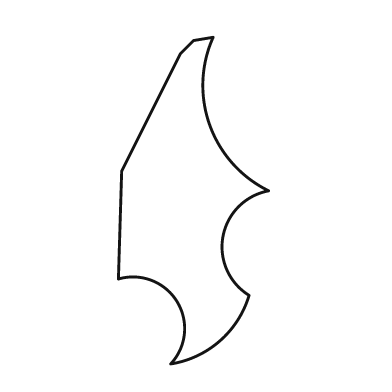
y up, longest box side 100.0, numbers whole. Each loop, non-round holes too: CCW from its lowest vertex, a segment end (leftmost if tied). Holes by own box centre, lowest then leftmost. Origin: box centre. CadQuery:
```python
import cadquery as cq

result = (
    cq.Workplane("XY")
    .moveTo(-7.0, -50.0)
    .threePointArc((8.0, -43.0), (17.0, -29.0))
    .threePointArc((9.0, -11.0), (23.0, 3.0))
    .threePointArc((5.0, 23.0), (6.0, 50.0))
    .lineTo(0.0, 49.0)
    .lineTo(-4.0, 45.0)
    .lineTo(-22.0, 9.0)
    .lineTo(-23.0, -24.0)
    .threePointArc((-5.0, -31.0), (-7.0, -50.0))
    .close()
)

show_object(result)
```